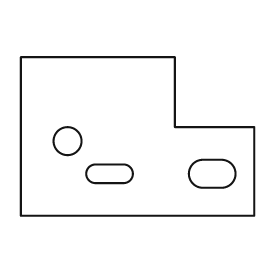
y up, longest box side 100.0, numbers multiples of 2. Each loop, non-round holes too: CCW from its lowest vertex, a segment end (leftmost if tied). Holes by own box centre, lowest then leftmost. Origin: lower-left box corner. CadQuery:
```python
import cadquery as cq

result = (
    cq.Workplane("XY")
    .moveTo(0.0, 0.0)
    .lineTo(100.0, 0.0)
    .lineTo(100.0, 38.0)
    .lineTo(66.0, 38.0)
    .lineTo(66.0, 68.0)
    .lineTo(0.0, 68.0)
    .close()
    .moveTo(32.0, 14.0)
    .lineTo(44.0, 14.0)
    .threePointArc((48.0, 18.0), (44.0, 22.0))
    .lineTo(32.0, 22.0)
    .threePointArc((28.0, 18.0), (32.0, 14.0))
    .close()
    .moveTo(78.0, 12.0)
    .lineTo(86.0, 12.0)
    .threePointArc((92.0, 18.0), (86.0, 24.0))
    .lineTo(78.0, 24.0)
    .threePointArc((72.0, 18.0), (78.0, 12.0))
    .close()
    .moveTo(20.0, 32.0)
    .circle(6.0)
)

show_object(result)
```